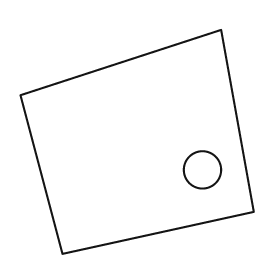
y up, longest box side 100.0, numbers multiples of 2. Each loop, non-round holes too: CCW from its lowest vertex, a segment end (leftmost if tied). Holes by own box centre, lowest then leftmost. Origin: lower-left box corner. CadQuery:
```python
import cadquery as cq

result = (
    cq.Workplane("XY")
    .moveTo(18.0, 0.0)
    .lineTo(100.0, 18.0)
    .lineTo(86.0, 96.0)
    .lineTo(0.0, 68.0)
    .close()
    .moveTo(78.0, 36.0)
    .circle(8.0)
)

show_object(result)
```